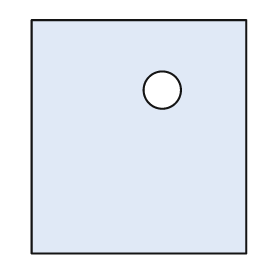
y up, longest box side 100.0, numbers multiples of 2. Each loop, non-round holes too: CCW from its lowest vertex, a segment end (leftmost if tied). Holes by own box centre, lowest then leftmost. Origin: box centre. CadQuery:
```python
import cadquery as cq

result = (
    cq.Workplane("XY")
    .moveTo(-46.0, -50.0)
    .lineTo(46.0, -50.0)
    .lineTo(46.0, 50.0)
    .lineTo(-46.0, 50.0)
    .close()
    .moveTo(10.0, 20.0)
    .circle(8.0)
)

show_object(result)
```